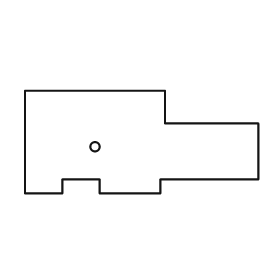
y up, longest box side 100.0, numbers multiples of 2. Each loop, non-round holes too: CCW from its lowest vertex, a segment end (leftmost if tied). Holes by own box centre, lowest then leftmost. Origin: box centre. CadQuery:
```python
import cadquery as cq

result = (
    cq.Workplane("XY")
    .moveTo(-50.0, -22.0)
    .lineTo(-34.0, -22.0)
    .lineTo(-34.0, -16.0)
    .lineTo(-18.0, -16.0)
    .lineTo(-18.0, -22.0)
    .lineTo(8.0, -22.0)
    .lineTo(8.0, -16.0)
    .lineTo(50.0, -16.0)
    .lineTo(50.0, 8.0)
    .lineTo(10.0, 8.0)
    .lineTo(10.0, 22.0)
    .lineTo(-50.0, 22.0)
    .close()
    .moveTo(-20.0, -2.0)
    .circle(2.0)
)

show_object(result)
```